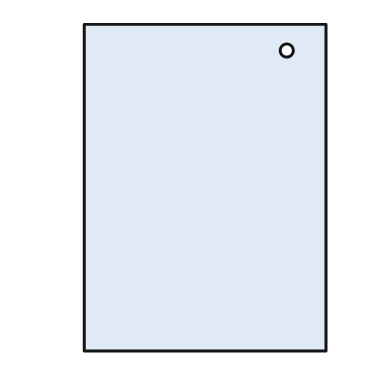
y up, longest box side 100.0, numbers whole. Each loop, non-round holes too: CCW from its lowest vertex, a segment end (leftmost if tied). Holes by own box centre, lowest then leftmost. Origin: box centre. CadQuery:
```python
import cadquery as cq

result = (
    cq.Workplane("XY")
    .moveTo(-37.0, -50.0)
    .lineTo(37.0, -50.0)
    .lineTo(37.0, 50.0)
    .lineTo(-37.0, 50.0)
    .close()
    .moveTo(25.0, 42.0)
    .circle(2.0)
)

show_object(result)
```